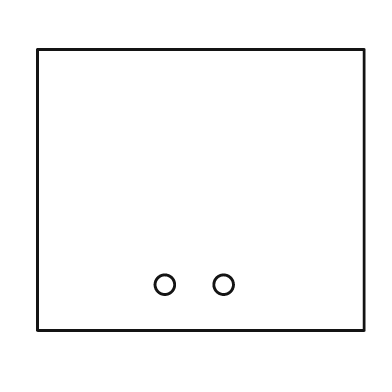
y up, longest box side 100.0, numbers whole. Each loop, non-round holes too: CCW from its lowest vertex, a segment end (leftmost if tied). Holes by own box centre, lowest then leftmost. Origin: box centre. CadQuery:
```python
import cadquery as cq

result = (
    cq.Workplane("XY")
    .moveTo(-50.0, -43.0)
    .lineTo(50.0, -43.0)
    .lineTo(50.0, 43.0)
    .lineTo(-50.0, 43.0)
    .close()
    .moveTo(-11.0, -29.0)
    .circle(3.0)
    .moveTo(7.0, -29.0)
    .circle(3.0)
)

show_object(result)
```